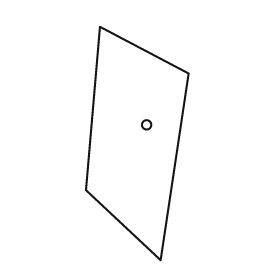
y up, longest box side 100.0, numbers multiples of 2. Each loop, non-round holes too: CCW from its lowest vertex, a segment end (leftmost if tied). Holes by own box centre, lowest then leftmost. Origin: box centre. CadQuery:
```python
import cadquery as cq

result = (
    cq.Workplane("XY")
    .moveTo(10.0, -50.0)
    .lineTo(22.0, 30.0)
    .lineTo(-16.0, 50.0)
    .lineTo(-22.0, -20.0)
    .close()
    .moveTo(4.0, 8.0)
    .circle(2.0)
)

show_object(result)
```